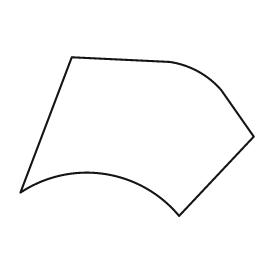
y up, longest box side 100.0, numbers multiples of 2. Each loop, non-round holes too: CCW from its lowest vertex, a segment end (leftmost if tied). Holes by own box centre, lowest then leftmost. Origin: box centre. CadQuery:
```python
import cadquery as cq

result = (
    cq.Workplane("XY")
    .moveTo(18.0, -34.0)
    .lineTo(50.0, 0.0)
    .lineTo(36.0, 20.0)
    .threePointArc((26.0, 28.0), (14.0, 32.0))
    .lineTo(-28.0, 34.0)
    .lineTo(-50.0, -24.0)
    .threePointArc((-14.0, -16.0), (18.0, -34.0))
    .close()
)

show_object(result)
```